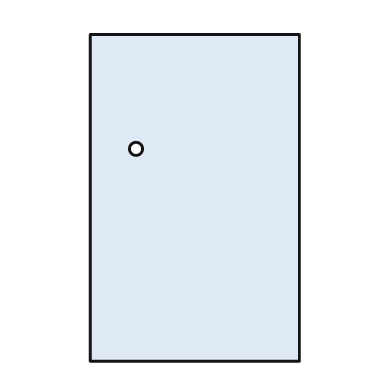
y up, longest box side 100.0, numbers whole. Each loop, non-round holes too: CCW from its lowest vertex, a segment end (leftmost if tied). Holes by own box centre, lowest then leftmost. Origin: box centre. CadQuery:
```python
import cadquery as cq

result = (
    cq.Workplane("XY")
    .moveTo(-32.0, -50.0)
    .lineTo(32.0, -50.0)
    .lineTo(32.0, 50.0)
    .lineTo(-32.0, 50.0)
    .close()
    .moveTo(-18.0, 15.0)
    .circle(2.0)
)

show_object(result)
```